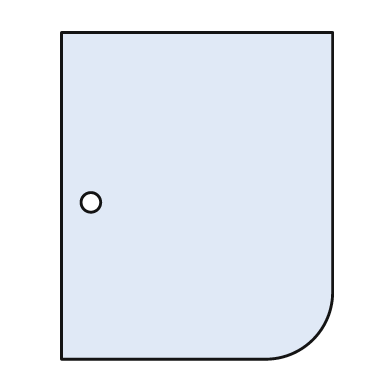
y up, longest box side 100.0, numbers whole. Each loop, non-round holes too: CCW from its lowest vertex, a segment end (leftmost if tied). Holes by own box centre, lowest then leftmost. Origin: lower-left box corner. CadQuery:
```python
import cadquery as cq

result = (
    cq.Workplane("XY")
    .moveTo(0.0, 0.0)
    .lineTo(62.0, 0.0)
    .threePointArc((77.0, 6.0), (83.0, 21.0))
    .lineTo(83.0, 100.0)
    .lineTo(0.0, 100.0)
    .close()
    .moveTo(9.0, 48.0)
    .circle(3.0)
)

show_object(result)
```